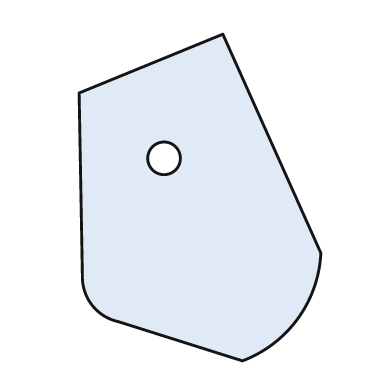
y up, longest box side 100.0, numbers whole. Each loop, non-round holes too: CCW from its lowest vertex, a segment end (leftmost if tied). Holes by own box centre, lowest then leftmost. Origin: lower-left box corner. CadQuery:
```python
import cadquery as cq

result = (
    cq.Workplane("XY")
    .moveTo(50.0, 0.0)
    .threePointArc((67.0, 13.0), (74.0, 33.0))
    .lineTo(44.0, 100.0)
    .lineTo(0.0, 82.0)
    .lineTo(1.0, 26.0)
    .threePointArc((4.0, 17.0), (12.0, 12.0))
    .close()
    .moveTo(26.0, 62.0)
    .circle(5.0)
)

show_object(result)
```